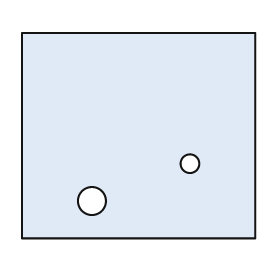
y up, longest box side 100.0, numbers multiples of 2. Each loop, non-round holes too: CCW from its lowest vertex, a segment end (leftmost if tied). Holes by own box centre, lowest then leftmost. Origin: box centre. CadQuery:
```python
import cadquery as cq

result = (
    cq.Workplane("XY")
    .moveTo(-50.0, -44.0)
    .lineTo(50.0, -44.0)
    .lineTo(50.0, 44.0)
    .lineTo(-50.0, 44.0)
    .close()
    .moveTo(-20.0, -28.0)
    .circle(6.0)
    .moveTo(22.0, -12.0)
    .circle(4.0)
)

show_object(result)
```